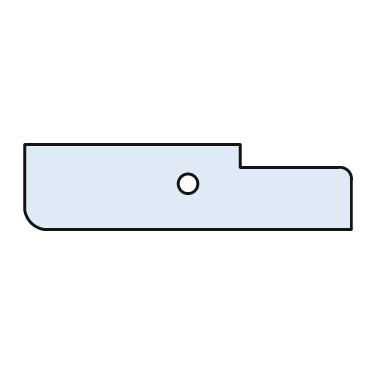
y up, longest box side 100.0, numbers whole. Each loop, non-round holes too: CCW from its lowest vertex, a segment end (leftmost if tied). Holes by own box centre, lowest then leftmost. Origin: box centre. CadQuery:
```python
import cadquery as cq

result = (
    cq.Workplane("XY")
    .moveTo(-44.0, -13.0)
    .lineTo(50.0, -13.0)
    .lineTo(50.0, 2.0)
    .threePointArc((49.0, 5.0), (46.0, 6.0))
    .lineTo(16.0, 6.0)
    .lineTo(16.0, 13.0)
    .lineTo(-50.0, 13.0)
    .lineTo(-50.0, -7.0)
    .threePointArc((-48.0, -11.0), (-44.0, -13.0))
    .close()
    .moveTo(0.0, 1.0)
    .circle(3.0)
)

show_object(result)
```